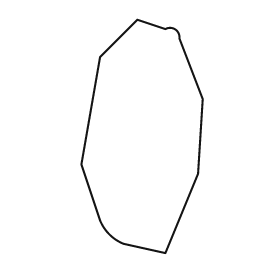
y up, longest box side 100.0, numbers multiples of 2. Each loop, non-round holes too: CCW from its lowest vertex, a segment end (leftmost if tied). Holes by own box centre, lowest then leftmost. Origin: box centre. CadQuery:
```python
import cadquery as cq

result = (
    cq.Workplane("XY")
    .moveTo(10.0, -50.0)
    .lineTo(24.0, -16.0)
    .lineTo(26.0, 16.0)
    .lineTo(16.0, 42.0)
    .threePointArc((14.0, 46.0), (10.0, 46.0))
    .lineTo(-2.0, 50.0)
    .lineTo(-18.0, 34.0)
    .lineTo(-26.0, -12.0)
    .lineTo(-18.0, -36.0)
    .threePointArc((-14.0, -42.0), (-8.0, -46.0))
    .close()
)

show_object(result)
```